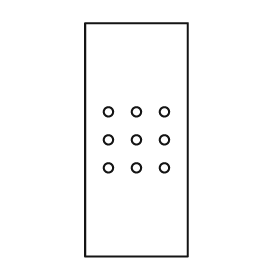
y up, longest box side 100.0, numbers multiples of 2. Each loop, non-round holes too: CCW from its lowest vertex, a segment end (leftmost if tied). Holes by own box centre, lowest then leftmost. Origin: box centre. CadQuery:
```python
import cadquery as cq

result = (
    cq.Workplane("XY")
    .moveTo(-22.0, -50.0)
    .lineTo(22.0, -50.0)
    .lineTo(22.0, 50.0)
    .lineTo(-22.0, 50.0)
    .close()
    .moveTo(-12.0, -12.0)
    .circle(2.0)
    .moveTo(0.0, -12.0)
    .circle(2.0)
    .moveTo(12.0, -12.0)
    .circle(2.0)
    .moveTo(-12.0, 0.0)
    .circle(2.0)
    .moveTo(0.0, 0.0)
    .circle(2.0)
    .moveTo(12.0, 0.0)
    .circle(2.0)
    .moveTo(-12.0, 12.0)
    .circle(2.0)
    .moveTo(0.0, 12.0)
    .circle(2.0)
    .moveTo(12.0, 12.0)
    .circle(2.0)
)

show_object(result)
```